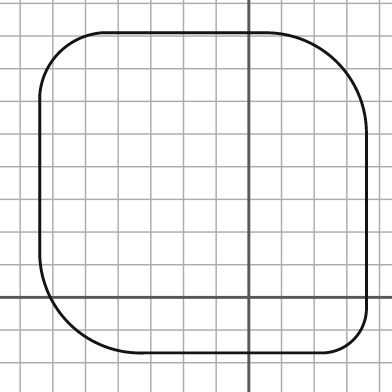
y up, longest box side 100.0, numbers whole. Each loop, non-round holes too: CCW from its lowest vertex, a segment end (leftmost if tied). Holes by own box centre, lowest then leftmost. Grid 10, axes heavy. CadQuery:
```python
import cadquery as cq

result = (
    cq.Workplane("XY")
    .moveTo(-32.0, -17.0)
    .lineTo(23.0, -17.0)
    .threePointArc((32.0, -13.0), (36.0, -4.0))
    .lineTo(36.0, 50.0)
    .threePointArc((27.0, 72.0), (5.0, 81.0))
    .lineTo(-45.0, 81.0)
    .threePointArc((-58.0, 75.0), (-64.0, 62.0))
    .lineTo(-64.0, 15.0)
    .threePointArc((-55.0, -8.0), (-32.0, -17.0))
    .close()
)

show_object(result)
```